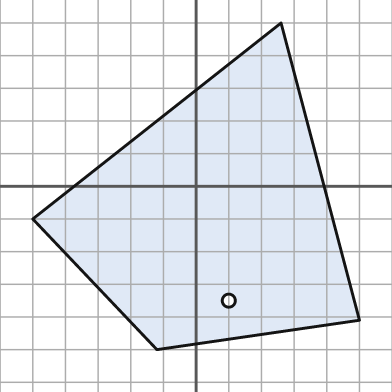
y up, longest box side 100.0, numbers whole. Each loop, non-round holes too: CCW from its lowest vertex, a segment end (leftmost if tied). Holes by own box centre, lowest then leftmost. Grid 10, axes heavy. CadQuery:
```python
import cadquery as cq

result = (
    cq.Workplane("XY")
    .moveTo(-12.0, -50.0)
    .lineTo(50.0, -41.0)
    .lineTo(26.0, 50.0)
    .lineTo(-50.0, -10.0)
    .close()
    .moveTo(10.0, -35.0)
    .circle(2.0)
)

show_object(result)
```